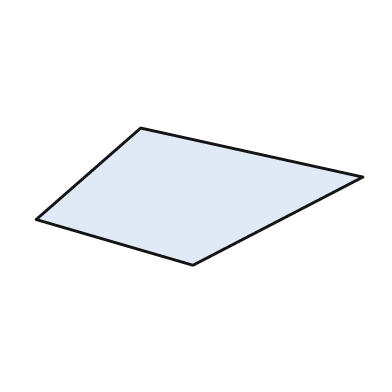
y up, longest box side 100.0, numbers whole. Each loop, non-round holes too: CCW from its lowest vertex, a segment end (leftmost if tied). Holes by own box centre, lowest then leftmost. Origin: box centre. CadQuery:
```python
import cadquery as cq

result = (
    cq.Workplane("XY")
    .moveTo(-2.0, -21.0)
    .lineTo(50.0, 6.0)
    .lineTo(-18.0, 21.0)
    .lineTo(-50.0, -7.0)
    .close()
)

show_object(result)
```